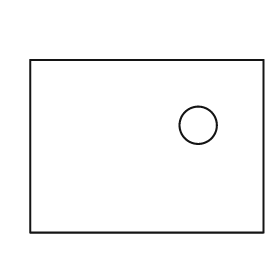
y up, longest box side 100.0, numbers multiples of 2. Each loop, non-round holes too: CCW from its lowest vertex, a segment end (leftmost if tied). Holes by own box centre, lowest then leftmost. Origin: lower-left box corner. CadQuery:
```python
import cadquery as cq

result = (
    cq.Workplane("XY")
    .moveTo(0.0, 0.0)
    .lineTo(100.0, 0.0)
    .lineTo(100.0, 74.0)
    .lineTo(0.0, 74.0)
    .close()
    .moveTo(72.0, 46.0)
    .circle(8.0)
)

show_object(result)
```